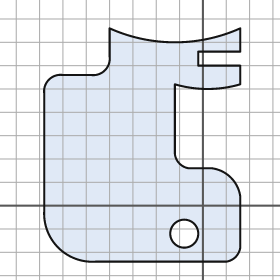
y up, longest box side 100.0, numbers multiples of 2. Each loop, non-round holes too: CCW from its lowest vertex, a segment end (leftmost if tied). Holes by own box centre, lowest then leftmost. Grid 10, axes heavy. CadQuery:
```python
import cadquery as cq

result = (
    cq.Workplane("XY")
    .moveTo(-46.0, -24.0)
    .lineTo(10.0, -24.0)
    .threePointArc((14.0, -22.0), (16.0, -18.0))
    .lineTo(16.0, 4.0)
    .threePointArc((12.0, 12.0), (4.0, 16.0))
    .lineTo(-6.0, 16.0)
    .threePointArc((-10.0, 18.0), (-12.0, 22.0))
    .lineTo(-12.0, 52.0)
    .threePointArc((2.0, 50.0), (16.0, 52.0))
    .lineTo(16.0, 60.0)
    .lineTo(-2.0, 60.0)
    .lineTo(-2.0, 66.0)
    .lineTo(16.0, 66.0)
    .lineTo(16.0, 76.0)
    .threePointArc((-12.0, 70.0), (-40.0, 76.0))
    .lineTo(-40.0, 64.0)
    .threePointArc((-42.0, 58.0), (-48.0, 56.0))
    .lineTo(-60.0, 56.0)
    .threePointArc((-66.0, 54.0), (-68.0, 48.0))
    .lineTo(-68.0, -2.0)
    .threePointArc((-62.0, -18.0), (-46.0, -24.0))
    .close()
    .moveTo(-8.0, -12.0)
    .circle(6.0)
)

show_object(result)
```